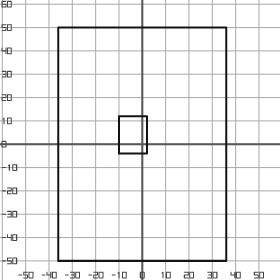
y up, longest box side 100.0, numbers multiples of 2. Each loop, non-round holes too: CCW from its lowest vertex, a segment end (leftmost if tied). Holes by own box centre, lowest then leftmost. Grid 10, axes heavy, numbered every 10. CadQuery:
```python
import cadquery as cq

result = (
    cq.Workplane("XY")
    .moveTo(-36.0, -50.0)
    .lineTo(36.0, -50.0)
    .lineTo(36.0, 50.0)
    .lineTo(-36.0, 50.0)
    .close()
    .moveTo(-10.0, -4.0)
    .lineTo(2.0, -4.0)
    .lineTo(2.0, 12.0)
    .lineTo(-10.0, 12.0)
    .close()
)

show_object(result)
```